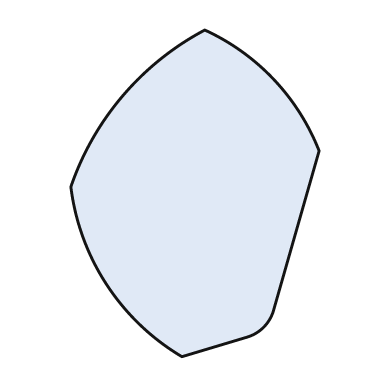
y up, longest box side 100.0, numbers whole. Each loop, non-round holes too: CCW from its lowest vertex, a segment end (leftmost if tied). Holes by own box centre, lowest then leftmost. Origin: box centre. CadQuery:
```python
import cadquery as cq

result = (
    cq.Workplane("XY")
    .moveTo(-4.0, -50.0)
    .lineTo(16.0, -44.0)
    .threePointArc((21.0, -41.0), (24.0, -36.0))
    .lineTo(38.0, 13.0)
    .threePointArc((24.0, 35.0), (3.0, 50.0))
    .threePointArc((-22.0, 30.0), (-38.0, 2.0))
    .threePointArc((-27.0, -28.0), (-4.0, -50.0))
    .close()
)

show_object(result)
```